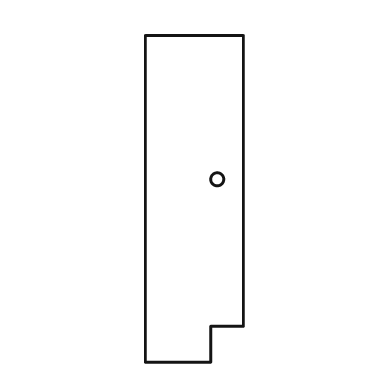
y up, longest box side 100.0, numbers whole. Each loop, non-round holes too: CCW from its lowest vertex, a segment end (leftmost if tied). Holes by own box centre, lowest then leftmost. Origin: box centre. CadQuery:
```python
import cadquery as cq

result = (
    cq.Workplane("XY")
    .moveTo(-15.0, -50.0)
    .lineTo(5.0, -50.0)
    .lineTo(5.0, -39.0)
    .lineTo(15.0, -39.0)
    .lineTo(15.0, 50.0)
    .lineTo(-15.0, 50.0)
    .close()
    .moveTo(7.0, 6.0)
    .circle(2.0)
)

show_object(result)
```